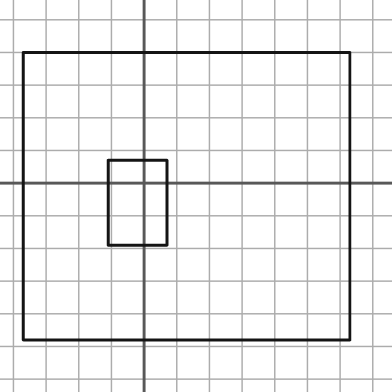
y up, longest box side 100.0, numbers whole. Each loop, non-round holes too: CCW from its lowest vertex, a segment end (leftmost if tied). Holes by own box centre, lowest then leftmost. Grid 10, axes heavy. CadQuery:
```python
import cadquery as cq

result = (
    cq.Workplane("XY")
    .moveTo(-37.0, -48.0)
    .lineTo(63.0, -48.0)
    .lineTo(63.0, 40.0)
    .lineTo(-37.0, 40.0)
    .close()
    .moveTo(-11.0, -19.0)
    .lineTo(7.0, -19.0)
    .lineTo(7.0, 7.0)
    .lineTo(-11.0, 7.0)
    .close()
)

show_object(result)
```